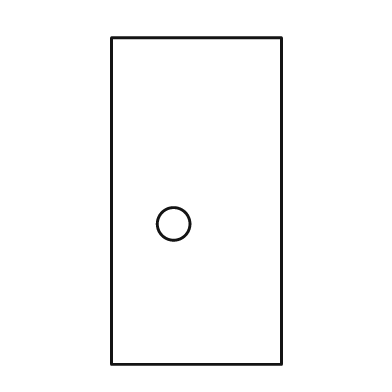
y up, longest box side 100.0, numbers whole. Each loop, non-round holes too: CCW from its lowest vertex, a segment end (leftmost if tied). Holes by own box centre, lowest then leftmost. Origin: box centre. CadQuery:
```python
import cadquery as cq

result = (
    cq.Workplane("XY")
    .moveTo(-26.0, -50.0)
    .lineTo(26.0, -50.0)
    .lineTo(26.0, 50.0)
    .lineTo(-26.0, 50.0)
    .close()
    .moveTo(-7.0, -7.0)
    .circle(5.0)
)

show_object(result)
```